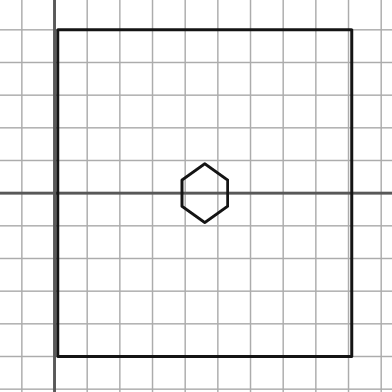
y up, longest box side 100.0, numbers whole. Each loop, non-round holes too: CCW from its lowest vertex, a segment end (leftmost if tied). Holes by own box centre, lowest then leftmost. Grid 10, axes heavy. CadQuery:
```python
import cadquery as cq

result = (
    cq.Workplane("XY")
    .moveTo(1.0, -50.0)
    .lineTo(91.0, -50.0)
    .lineTo(91.0, 50.0)
    .lineTo(1.0, 50.0)
    .close()
    .moveTo(46.0, -9.0)
    .lineTo(53.0, -4.0)
    .lineTo(53.0, 4.0)
    .lineTo(46.0, 9.0)
    .lineTo(39.0, 4.0)
    .lineTo(39.0, -4.0)
    .close()
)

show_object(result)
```